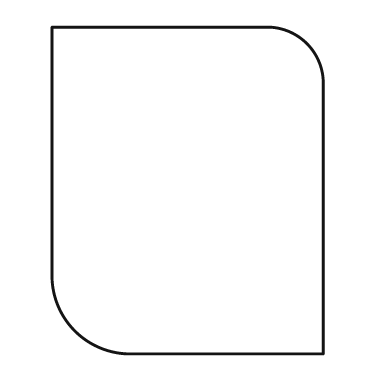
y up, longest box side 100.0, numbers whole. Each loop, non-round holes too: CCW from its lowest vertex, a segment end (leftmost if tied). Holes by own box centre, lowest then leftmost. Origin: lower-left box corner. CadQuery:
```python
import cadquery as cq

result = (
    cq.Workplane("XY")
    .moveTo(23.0, 0.0)
    .lineTo(83.0, 0.0)
    .lineTo(83.0, 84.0)
    .threePointArc((78.0, 95.0), (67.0, 100.0))
    .lineTo(0.0, 100.0)
    .lineTo(0.0, 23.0)
    .threePointArc((7.0, 7.0), (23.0, 0.0))
    .close()
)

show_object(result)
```